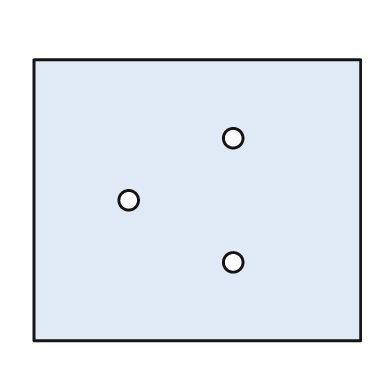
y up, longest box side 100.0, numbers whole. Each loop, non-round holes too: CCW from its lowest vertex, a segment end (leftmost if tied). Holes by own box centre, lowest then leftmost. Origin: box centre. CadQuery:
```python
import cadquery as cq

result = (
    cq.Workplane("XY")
    .moveTo(-50.0, -43.0)
    .lineTo(50.0, -43.0)
    .lineTo(50.0, 43.0)
    .lineTo(-50.0, 43.0)
    .close()
    .moveTo(11.0, -19.0)
    .circle(3.0)
    .moveTo(-21.0, 0.0)
    .circle(3.0)
    .moveTo(11.0, 19.0)
    .circle(3.0)
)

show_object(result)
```